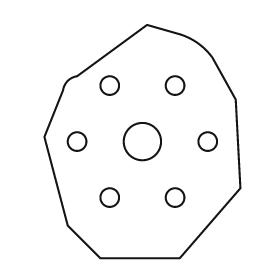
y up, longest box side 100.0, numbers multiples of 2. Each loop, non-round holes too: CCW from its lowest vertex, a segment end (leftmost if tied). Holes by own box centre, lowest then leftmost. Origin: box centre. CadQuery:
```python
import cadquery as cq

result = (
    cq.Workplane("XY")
    .moveTo(-18.0, -50.0)
    .lineTo(16.0, -50.0)
    .lineTo(42.0, -20.0)
    .lineTo(40.0, 18.0)
    .lineTo(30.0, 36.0)
    .threePointArc((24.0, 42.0), (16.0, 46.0))
    .lineTo(2.0, 50.0)
    .lineTo(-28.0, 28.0)
    .threePointArc((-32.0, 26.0), (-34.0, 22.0))
    .lineTo(-42.0, 2.0)
    .lineTo(-32.0, -36.0)
    .close()
    .moveTo(-14.0, -24.0)
    .circle(4.0)
    .moveTo(14.0, -24.0)
    .circle(4.0)
    .moveTo(-28.0, 0.0)
    .circle(4.0)
    .moveTo(0.0, 0.0)
    .circle(8.0)
    .moveTo(28.0, 0.0)
    .circle(4.0)
    .moveTo(-14.0, 24.0)
    .circle(4.0)
    .moveTo(14.0, 24.0)
    .circle(4.0)
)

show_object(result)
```